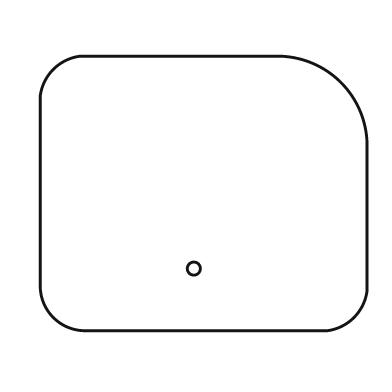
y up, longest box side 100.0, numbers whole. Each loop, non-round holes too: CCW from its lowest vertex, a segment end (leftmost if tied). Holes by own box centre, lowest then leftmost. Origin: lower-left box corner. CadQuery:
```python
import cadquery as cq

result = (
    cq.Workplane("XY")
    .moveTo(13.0, 0.0)
    .lineTo(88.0, 0.0)
    .threePointArc((96.0, 4.0), (100.0, 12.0))
    .lineTo(100.0, 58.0)
    .threePointArc((92.0, 76.0), (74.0, 84.0))
    .lineTo(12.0, 84.0)
    .threePointArc((4.0, 80.0), (0.0, 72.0))
    .lineTo(0.0, 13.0)
    .threePointArc((4.0, 4.0), (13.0, 0.0))
    .close()
    .moveTo(47.0, 19.0)
    .circle(2.0)
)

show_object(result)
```